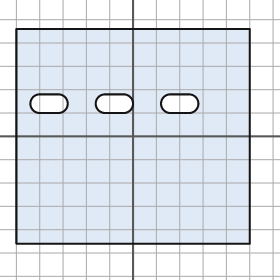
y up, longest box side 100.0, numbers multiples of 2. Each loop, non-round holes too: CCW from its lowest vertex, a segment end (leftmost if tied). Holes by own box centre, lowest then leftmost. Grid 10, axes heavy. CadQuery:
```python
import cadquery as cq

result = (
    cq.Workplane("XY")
    .moveTo(-50.0, -46.0)
    .lineTo(50.0, -46.0)
    .lineTo(50.0, 46.0)
    .lineTo(-50.0, 46.0)
    .close()
    .moveTo(-40.0, 10.0)
    .lineTo(-32.0, 10.0)
    .threePointArc((-28.0, 14.0), (-32.0, 18.0))
    .lineTo(-40.0, 18.0)
    .threePointArc((-44.0, 14.0), (-40.0, 10.0))
    .close()
    .moveTo(-12.0, 10.0)
    .lineTo(-4.0, 10.0)
    .threePointArc((0.0, 14.0), (-4.0, 18.0))
    .lineTo(-12.0, 18.0)
    .threePointArc((-16.0, 14.0), (-12.0, 10.0))
    .close()
    .moveTo(16.0, 10.0)
    .lineTo(24.0, 10.0)
    .threePointArc((28.0, 14.0), (24.0, 18.0))
    .lineTo(16.0, 18.0)
    .threePointArc((12.0, 14.0), (16.0, 10.0))
    .close()
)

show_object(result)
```